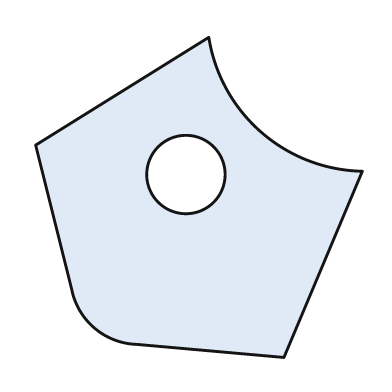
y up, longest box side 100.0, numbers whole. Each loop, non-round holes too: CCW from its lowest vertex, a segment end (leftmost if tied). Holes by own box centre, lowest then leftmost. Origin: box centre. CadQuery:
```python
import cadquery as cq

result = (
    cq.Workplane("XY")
    .moveTo(26.0, -49.0)
    .lineTo(50.0, 8.0)
    .threePointArc((19.0, 20.0), (3.0, 49.0))
    .lineTo(-50.0, 16.0)
    .lineTo(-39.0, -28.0)
    .threePointArc((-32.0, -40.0), (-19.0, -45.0))
    .close()
    .moveTo(-4.0, 7.0)
    .circle(12.0)
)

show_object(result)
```